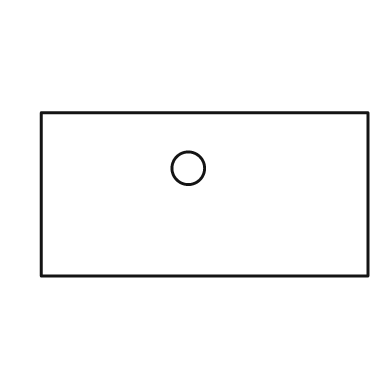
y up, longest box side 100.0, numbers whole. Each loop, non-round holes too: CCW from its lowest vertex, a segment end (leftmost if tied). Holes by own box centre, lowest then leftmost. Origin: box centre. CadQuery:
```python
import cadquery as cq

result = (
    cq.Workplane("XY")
    .moveTo(-50.0, -25.0)
    .lineTo(50.0, -25.0)
    .lineTo(50.0, 25.0)
    .lineTo(-50.0, 25.0)
    .close()
    .moveTo(-5.0, 8.0)
    .circle(5.0)
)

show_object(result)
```